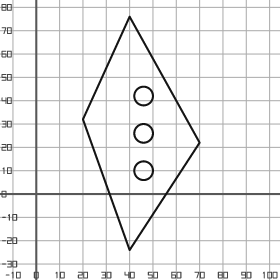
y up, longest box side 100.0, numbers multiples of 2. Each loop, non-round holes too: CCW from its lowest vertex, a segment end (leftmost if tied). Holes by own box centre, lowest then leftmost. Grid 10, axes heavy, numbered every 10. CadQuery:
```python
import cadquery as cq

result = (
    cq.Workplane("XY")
    .moveTo(40.0, -24.0)
    .lineTo(70.0, 22.0)
    .lineTo(40.0, 76.0)
    .lineTo(20.0, 32.0)
    .close()
    .moveTo(46.0, 10.0)
    .circle(4.0)
    .moveTo(46.0, 26.0)
    .circle(4.0)
    .moveTo(46.0, 42.0)
    .circle(4.0)
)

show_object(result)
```